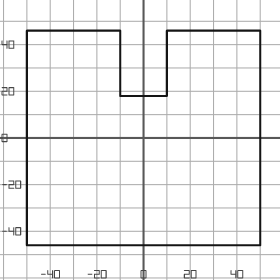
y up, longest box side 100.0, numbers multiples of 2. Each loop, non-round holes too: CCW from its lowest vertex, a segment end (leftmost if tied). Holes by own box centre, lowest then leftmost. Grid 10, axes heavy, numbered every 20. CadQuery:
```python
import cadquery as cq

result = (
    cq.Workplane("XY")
    .moveTo(-50.0, -46.0)
    .lineTo(50.0, -46.0)
    .lineTo(50.0, 46.0)
    .lineTo(10.0, 46.0)
    .lineTo(10.0, 18.0)
    .lineTo(-10.0, 18.0)
    .lineTo(-10.0, 46.0)
    .lineTo(-50.0, 46.0)
    .close()
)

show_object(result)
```